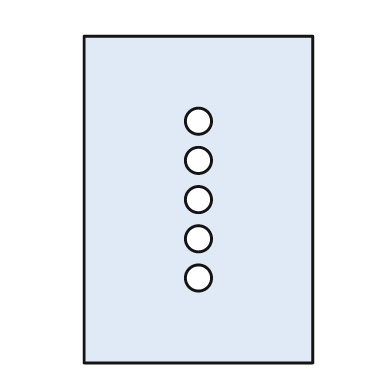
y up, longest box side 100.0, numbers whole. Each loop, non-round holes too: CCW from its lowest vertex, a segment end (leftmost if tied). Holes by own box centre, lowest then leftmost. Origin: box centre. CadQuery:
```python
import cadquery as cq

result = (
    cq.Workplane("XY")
    .moveTo(-35.0, -50.0)
    .lineTo(35.0, -50.0)
    .lineTo(35.0, 50.0)
    .lineTo(-35.0, 50.0)
    .close()
    .moveTo(0.0, -24.0)
    .circle(4.0)
    .moveTo(0.0, -12.0)
    .circle(4.0)
    .moveTo(0.0, 0.0)
    .circle(4.0)
    .moveTo(0.0, 12.0)
    .circle(4.0)
    .moveTo(0.0, 24.0)
    .circle(4.0)
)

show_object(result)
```